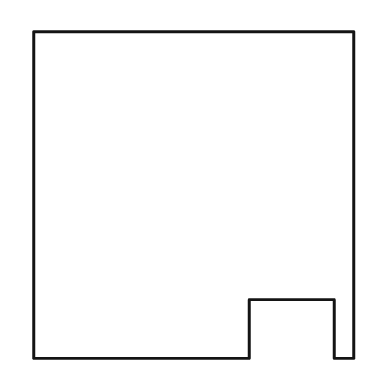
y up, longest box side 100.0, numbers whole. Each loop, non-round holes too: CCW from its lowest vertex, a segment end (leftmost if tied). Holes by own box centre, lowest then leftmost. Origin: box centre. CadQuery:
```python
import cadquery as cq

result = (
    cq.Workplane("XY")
    .moveTo(-49.0, -50.0)
    .lineTo(17.0, -50.0)
    .lineTo(17.0, -32.0)
    .lineTo(43.0, -32.0)
    .lineTo(43.0, -50.0)
    .lineTo(49.0, -50.0)
    .lineTo(49.0, 50.0)
    .lineTo(-49.0, 50.0)
    .close()
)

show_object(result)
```